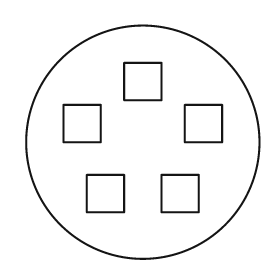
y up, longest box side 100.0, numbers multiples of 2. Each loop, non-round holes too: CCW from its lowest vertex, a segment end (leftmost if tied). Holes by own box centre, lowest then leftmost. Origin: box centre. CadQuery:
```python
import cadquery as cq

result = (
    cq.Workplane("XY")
    .moveTo(0.0, 0.0)
    .circle(50.0)
    .moveTo(-24.0, -30.0)
    .lineTo(-8.0, -30.0)
    .lineTo(-8.0, -14.0)
    .lineTo(-24.0, -14.0)
    .close()
    .moveTo(8.0, -30.0)
    .lineTo(24.0, -30.0)
    .lineTo(24.0, -14.0)
    .lineTo(8.0, -14.0)
    .close()
    .moveTo(-34.0, 0.0)
    .lineTo(-18.0, 0.0)
    .lineTo(-18.0, 16.0)
    .lineTo(-34.0, 16.0)
    .close()
    .moveTo(18.0, 0.0)
    .lineTo(34.0, 0.0)
    .lineTo(34.0, 16.0)
    .lineTo(18.0, 16.0)
    .close()
    .moveTo(-8.0, 18.0)
    .lineTo(8.0, 18.0)
    .lineTo(8.0, 34.0)
    .lineTo(-8.0, 34.0)
    .close()
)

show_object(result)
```